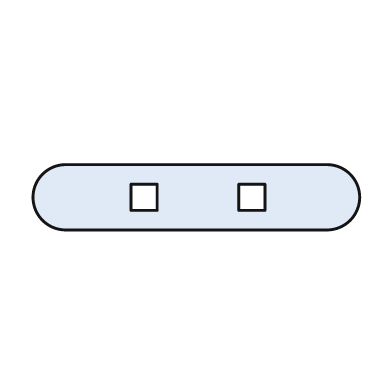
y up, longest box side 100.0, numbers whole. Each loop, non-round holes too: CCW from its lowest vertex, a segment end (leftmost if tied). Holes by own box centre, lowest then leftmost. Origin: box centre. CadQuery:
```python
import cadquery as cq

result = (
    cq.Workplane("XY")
    .moveTo(-40.0, -10.0)
    .lineTo(40.0, -10.0)
    .threePointArc((50.0, 0.0), (40.0, 10.0))
    .lineTo(-40.0, 10.0)
    .threePointArc((-50.0, 0.0), (-40.0, -10.0))
    .close()
    .moveTo(-20.0, -4.0)
    .lineTo(-12.0, -4.0)
    .lineTo(-12.0, 4.0)
    .lineTo(-20.0, 4.0)
    .close()
    .moveTo(13.0, -4.0)
    .lineTo(21.0, -4.0)
    .lineTo(21.0, 4.0)
    .lineTo(13.0, 4.0)
    .close()
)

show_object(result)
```